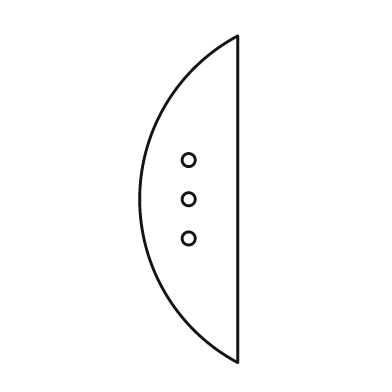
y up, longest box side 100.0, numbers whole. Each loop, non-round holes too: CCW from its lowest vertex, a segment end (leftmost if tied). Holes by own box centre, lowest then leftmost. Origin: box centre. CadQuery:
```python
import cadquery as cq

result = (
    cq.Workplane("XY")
    .moveTo(15.0, -50.0)
    .lineTo(15.0, 50.0)
    .threePointArc((-15.0, 0.0), (15.0, -50.0))
    .close()
    .moveTo(0.0, -12.0)
    .circle(2.0)
    .moveTo(0.0, 0.0)
    .circle(2.0)
    .moveTo(0.0, 12.0)
    .circle(2.0)
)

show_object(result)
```